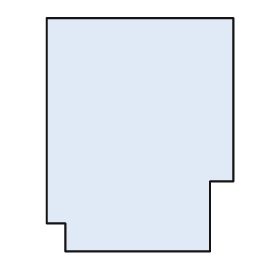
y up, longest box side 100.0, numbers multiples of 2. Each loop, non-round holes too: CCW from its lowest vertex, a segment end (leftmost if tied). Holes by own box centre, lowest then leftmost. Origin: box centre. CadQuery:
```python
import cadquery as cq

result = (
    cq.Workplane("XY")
    .moveTo(-32.0, -50.0)
    .lineTo(30.0, -50.0)
    .lineTo(30.0, -20.0)
    .lineTo(40.0, -20.0)
    .lineTo(40.0, 50.0)
    .lineTo(-40.0, 50.0)
    .lineTo(-40.0, -38.0)
    .lineTo(-32.0, -38.0)
    .close()
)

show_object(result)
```